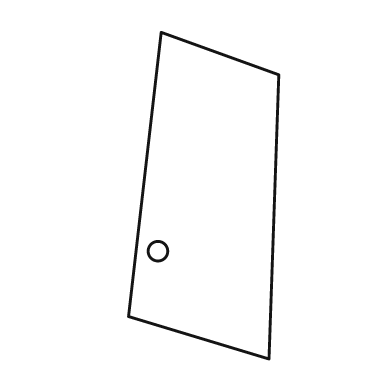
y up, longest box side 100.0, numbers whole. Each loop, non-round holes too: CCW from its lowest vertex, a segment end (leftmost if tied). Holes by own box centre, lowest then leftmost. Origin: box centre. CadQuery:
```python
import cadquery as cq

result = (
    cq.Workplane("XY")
    .moveTo(20.0, -50.0)
    .lineTo(23.0, 37.0)
    .lineTo(-13.0, 50.0)
    .lineTo(-23.0, -37.0)
    .close()
    .moveTo(-14.0, -17.0)
    .circle(3.0)
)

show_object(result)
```